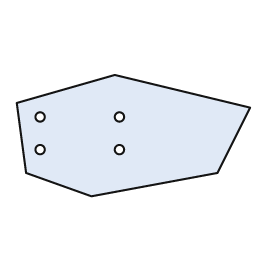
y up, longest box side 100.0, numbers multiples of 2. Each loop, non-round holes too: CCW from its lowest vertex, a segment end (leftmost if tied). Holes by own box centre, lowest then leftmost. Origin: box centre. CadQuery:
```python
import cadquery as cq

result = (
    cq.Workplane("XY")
    .moveTo(-18.0, -26.0)
    .lineTo(36.0, -16.0)
    .lineTo(50.0, 12.0)
    .lineTo(-8.0, 26.0)
    .lineTo(-50.0, 14.0)
    .lineTo(-46.0, -16.0)
    .close()
    .moveTo(-40.0, -6.0)
    .circle(2.0)
    .moveTo(-6.0, -6.0)
    .circle(2.0)
    .moveTo(-40.0, 8.0)
    .circle(2.0)
    .moveTo(-6.0, 8.0)
    .circle(2.0)
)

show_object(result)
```